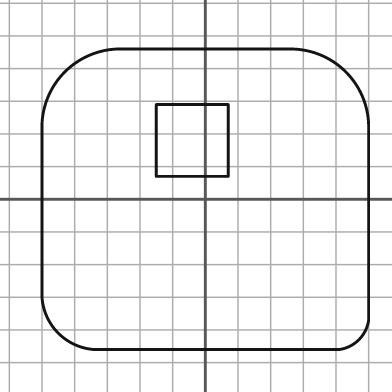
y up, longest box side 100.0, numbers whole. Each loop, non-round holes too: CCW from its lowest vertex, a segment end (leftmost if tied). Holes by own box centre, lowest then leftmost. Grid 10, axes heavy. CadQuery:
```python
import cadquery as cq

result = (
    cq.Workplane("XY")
    .moveTo(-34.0, -46.0)
    .lineTo(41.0, -46.0)
    .threePointArc((47.0, -43.0), (50.0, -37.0))
    .lineTo(50.0, 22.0)
    .threePointArc((43.0, 39.0), (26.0, 46.0))
    .lineTo(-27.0, 46.0)
    .threePointArc((-43.0, 39.0), (-50.0, 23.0))
    .lineTo(-50.0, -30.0)
    .threePointArc((-45.0, -41.0), (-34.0, -46.0))
    .close()
    .moveTo(-15.0, 7.0)
    .lineTo(7.0, 7.0)
    .lineTo(7.0, 29.0)
    .lineTo(-15.0, 29.0)
    .close()
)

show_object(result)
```